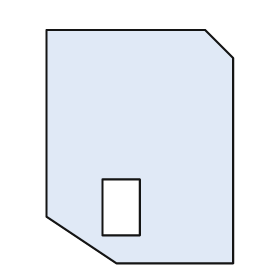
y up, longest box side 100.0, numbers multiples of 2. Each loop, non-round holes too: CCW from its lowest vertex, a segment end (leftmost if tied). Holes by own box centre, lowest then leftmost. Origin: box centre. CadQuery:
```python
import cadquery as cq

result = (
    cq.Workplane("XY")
    .moveTo(-10.0, -50.0)
    .lineTo(40.0, -50.0)
    .lineTo(40.0, 38.0)
    .lineTo(28.0, 50.0)
    .lineTo(-40.0, 50.0)
    .lineTo(-40.0, -30.0)
    .close()
    .moveTo(-16.0, -38.0)
    .lineTo(0.0, -38.0)
    .lineTo(0.0, -14.0)
    .lineTo(-16.0, -14.0)
    .close()
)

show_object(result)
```